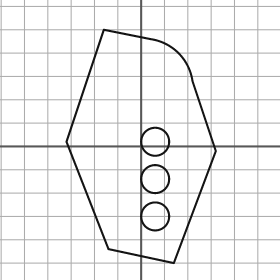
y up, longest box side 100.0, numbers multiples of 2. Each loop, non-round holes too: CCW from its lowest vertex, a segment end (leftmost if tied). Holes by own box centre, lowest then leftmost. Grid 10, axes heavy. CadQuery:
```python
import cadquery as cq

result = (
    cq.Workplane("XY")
    .moveTo(14.0, -50.0)
    .lineTo(32.0, -2.0)
    .lineTo(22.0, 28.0)
    .threePointArc((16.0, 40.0), (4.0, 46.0))
    .lineTo(-16.0, 50.0)
    .lineTo(-32.0, 2.0)
    .lineTo(-14.0, -44.0)
    .close()
    .moveTo(6.0, -30.0)
    .circle(6.0)
    .moveTo(6.0, -14.0)
    .circle(6.0)
    .moveTo(6.0, 2.0)
    .circle(6.0)
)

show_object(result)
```